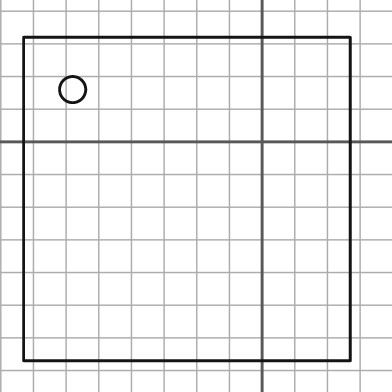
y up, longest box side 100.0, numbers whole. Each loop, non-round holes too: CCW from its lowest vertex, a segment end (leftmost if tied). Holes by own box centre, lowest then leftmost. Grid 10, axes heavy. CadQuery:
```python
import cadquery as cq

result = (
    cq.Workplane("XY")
    .moveTo(-73.0, -67.0)
    .lineTo(27.0, -67.0)
    .lineTo(27.0, 32.0)
    .lineTo(-73.0, 32.0)
    .close()
    .moveTo(-58.0, 16.0)
    .circle(4.0)
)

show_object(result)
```